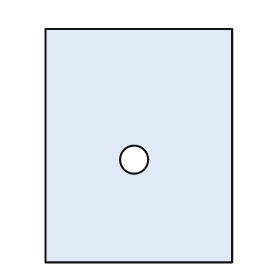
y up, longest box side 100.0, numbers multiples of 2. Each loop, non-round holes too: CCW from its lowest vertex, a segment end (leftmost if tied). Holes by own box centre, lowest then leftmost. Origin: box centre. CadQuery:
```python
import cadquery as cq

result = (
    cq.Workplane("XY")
    .moveTo(-40.0, -50.0)
    .lineTo(40.0, -50.0)
    .lineTo(40.0, 50.0)
    .lineTo(-40.0, 50.0)
    .close()
    .moveTo(-2.0, -6.0)
    .circle(6.0)
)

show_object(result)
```